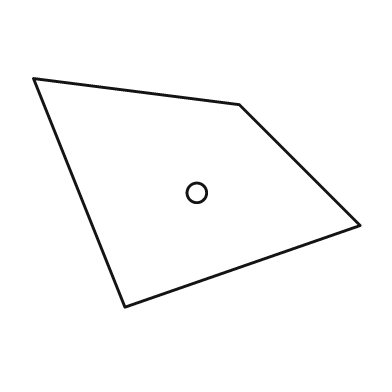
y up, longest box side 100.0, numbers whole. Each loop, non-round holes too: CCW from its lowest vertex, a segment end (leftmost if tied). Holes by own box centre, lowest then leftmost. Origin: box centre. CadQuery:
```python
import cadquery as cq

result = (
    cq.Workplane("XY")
    .moveTo(-22.0, -35.0)
    .lineTo(50.0, -10.0)
    .lineTo(13.0, 27.0)
    .lineTo(-50.0, 35.0)
    .close()
    .moveTo(0.0, 0.0)
    .circle(3.0)
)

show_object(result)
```